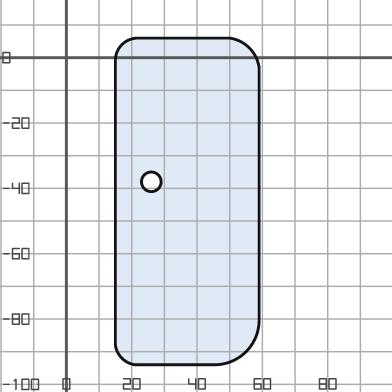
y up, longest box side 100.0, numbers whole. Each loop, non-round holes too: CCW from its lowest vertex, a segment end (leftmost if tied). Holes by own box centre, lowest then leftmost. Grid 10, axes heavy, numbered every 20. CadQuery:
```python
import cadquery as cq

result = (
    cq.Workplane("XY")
    .moveTo(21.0, -94.0)
    .lineTo(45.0, -94.0)
    .threePointArc((55.0, -90.0), (59.0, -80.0))
    .lineTo(59.0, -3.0)
    .threePointArc((56.0, 3.0), (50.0, 6.0))
    .lineTo(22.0, 6.0)
    .threePointArc((17.0, 4.0), (15.0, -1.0))
    .lineTo(15.0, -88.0)
    .threePointArc((17.0, -92.0), (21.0, -94.0))
    .close()
    .moveTo(26.0, -38.0)
    .circle(3.0)
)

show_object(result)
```